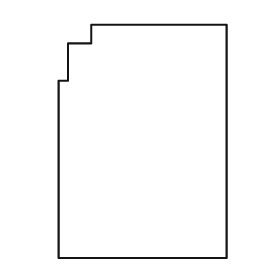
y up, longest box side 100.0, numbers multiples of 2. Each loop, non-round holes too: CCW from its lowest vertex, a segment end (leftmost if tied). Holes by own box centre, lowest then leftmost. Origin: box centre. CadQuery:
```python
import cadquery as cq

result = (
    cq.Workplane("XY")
    .moveTo(-36.0, -50.0)
    .lineTo(36.0, -50.0)
    .lineTo(36.0, 50.0)
    .lineTo(-22.0, 50.0)
    .lineTo(-22.0, 42.0)
    .lineTo(-32.0, 42.0)
    .lineTo(-32.0, 26.0)
    .lineTo(-36.0, 26.0)
    .close()
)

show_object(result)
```